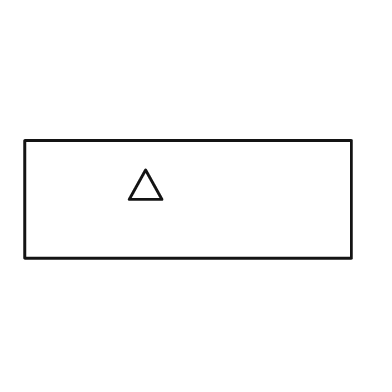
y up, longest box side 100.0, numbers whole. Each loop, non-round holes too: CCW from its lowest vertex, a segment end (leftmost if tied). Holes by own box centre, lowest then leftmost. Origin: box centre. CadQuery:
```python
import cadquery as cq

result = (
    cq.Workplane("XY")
    .moveTo(-50.0, -18.0)
    .lineTo(50.0, -18.0)
    .lineTo(50.0, 18.0)
    .lineTo(-50.0, 18.0)
    .close()
    .moveTo(-18.0, 0.0)
    .lineTo(-8.0, 0.0)
    .lineTo(-13.0, 9.0)
    .close()
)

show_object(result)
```